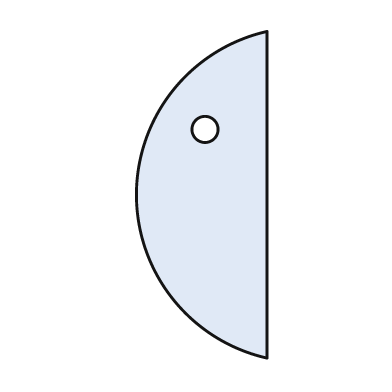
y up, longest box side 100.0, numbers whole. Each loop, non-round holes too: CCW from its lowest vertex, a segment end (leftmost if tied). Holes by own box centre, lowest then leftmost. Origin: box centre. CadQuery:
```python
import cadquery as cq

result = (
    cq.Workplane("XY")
    .moveTo(20.0, -50.0)
    .lineTo(20.0, 50.0)
    .threePointArc((-20.0, 0.0), (20.0, -50.0))
    .close()
    .moveTo(1.0, 20.0)
    .circle(4.0)
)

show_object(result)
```